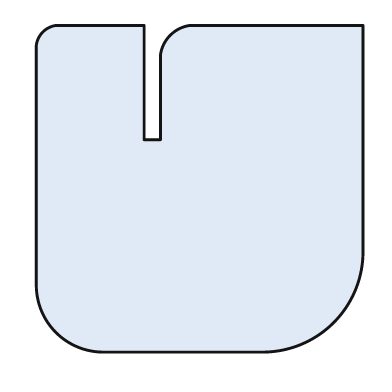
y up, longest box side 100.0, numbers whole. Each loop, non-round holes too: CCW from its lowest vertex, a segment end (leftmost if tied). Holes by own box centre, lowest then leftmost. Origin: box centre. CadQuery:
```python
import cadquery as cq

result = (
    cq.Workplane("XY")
    .moveTo(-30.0, -50.0)
    .lineTo(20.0, -50.0)
    .threePointArc((41.0, -41.0), (50.0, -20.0))
    .lineTo(50.0, 50.0)
    .lineTo(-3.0, 50.0)
    .threePointArc((-9.0, 47.0), (-12.0, 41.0))
    .lineTo(-12.0, 15.0)
    .lineTo(-17.0, 15.0)
    .lineTo(-17.0, 50.0)
    .lineTo(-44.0, 50.0)
    .threePointArc((-48.0, 48.0), (-50.0, 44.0))
    .lineTo(-50.0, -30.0)
    .threePointArc((-44.0, -44.0), (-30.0, -50.0))
    .close()
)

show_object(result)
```